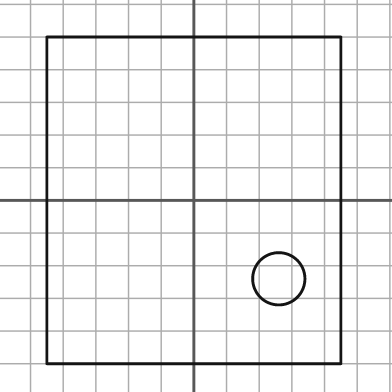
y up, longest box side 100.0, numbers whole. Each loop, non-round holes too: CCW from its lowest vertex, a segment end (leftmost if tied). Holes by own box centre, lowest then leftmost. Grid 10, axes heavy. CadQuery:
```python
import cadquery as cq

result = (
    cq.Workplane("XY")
    .moveTo(-45.0, -50.0)
    .lineTo(45.0, -50.0)
    .lineTo(45.0, 50.0)
    .lineTo(-45.0, 50.0)
    .close()
    .moveTo(26.0, -24.0)
    .circle(8.0)
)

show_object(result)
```